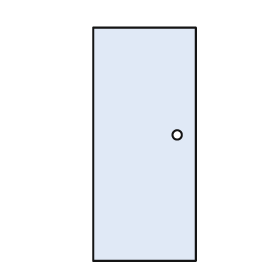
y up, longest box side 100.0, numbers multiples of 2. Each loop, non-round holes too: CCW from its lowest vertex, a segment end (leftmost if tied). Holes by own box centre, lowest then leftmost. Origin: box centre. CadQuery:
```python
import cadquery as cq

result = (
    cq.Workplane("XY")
    .moveTo(-22.0, -50.0)
    .lineTo(22.0, -50.0)
    .lineTo(22.0, 50.0)
    .lineTo(-22.0, 50.0)
    .close()
    .moveTo(14.0, 4.0)
    .circle(2.0)
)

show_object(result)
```